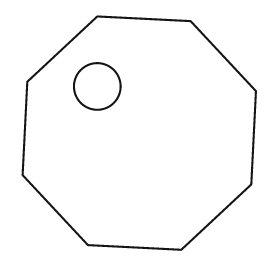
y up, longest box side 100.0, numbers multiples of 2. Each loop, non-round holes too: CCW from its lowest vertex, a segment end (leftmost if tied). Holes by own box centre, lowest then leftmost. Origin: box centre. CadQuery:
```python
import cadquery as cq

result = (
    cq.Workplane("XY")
    .moveTo(18.0, -50.0)
    .lineTo(48.0, -22.0)
    .lineTo(50.0, 18.0)
    .lineTo(22.0, 48.0)
    .lineTo(-18.0, 50.0)
    .lineTo(-48.0, 22.0)
    .lineTo(-50.0, -18.0)
    .lineTo(-22.0, -48.0)
    .close()
    .moveTo(-18.0, 20.0)
    .circle(10.0)
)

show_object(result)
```